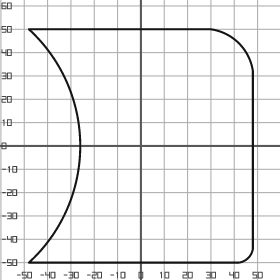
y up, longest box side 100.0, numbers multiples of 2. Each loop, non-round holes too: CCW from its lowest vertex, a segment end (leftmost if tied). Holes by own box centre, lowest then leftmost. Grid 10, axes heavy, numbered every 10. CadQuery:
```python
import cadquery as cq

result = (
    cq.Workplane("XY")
    .moveTo(-48.0, -50.0)
    .lineTo(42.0, -50.0)
    .threePointArc((46.0, -48.0), (48.0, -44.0))
    .lineTo(48.0, 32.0)
    .threePointArc((42.0, 44.0), (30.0, 50.0))
    .lineTo(-48.0, 50.0)
    .threePointArc((-26.0, 0.0), (-48.0, -50.0))
    .close()
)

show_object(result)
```